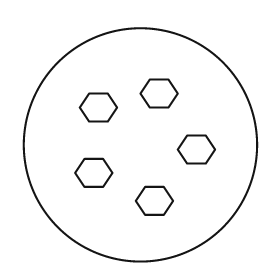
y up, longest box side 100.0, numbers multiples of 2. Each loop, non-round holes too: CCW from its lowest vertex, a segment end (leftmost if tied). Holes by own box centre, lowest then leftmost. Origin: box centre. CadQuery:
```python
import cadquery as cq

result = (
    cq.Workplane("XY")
    .moveTo(0.0, 0.0)
    .circle(50.0)
    .moveTo(2.0, -30.0)
    .lineTo(10.0, -30.0)
    .lineTo(14.0, -24.0)
    .lineTo(10.0, -18.0)
    .lineTo(2.0, -18.0)
    .lineTo(-2.0, -24.0)
    .close()
    .moveTo(-24.0, -18.0)
    .lineTo(-16.0, -18.0)
    .lineTo(-12.0, -12.0)
    .lineTo(-16.0, -6.0)
    .lineTo(-24.0, -6.0)
    .lineTo(-28.0, -12.0)
    .close()
    .moveTo(20.0, -8.0)
    .lineTo(28.0, -8.0)
    .lineTo(32.0, -2.0)
    .lineTo(28.0, 4.0)
    .lineTo(20.0, 4.0)
    .lineTo(16.0, -2.0)
    .close()
    .moveTo(-22.0, 10.0)
    .lineTo(-14.0, 10.0)
    .lineTo(-10.0, 16.0)
    .lineTo(-14.0, 22.0)
    .lineTo(-22.0, 22.0)
    .lineTo(-26.0, 16.0)
    .close()
    .moveTo(4.0, 16.0)
    .lineTo(12.0, 16.0)
    .lineTo(16.0, 22.0)
    .lineTo(12.0, 28.0)
    .lineTo(4.0, 28.0)
    .lineTo(0.0, 22.0)
    .close()
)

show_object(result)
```